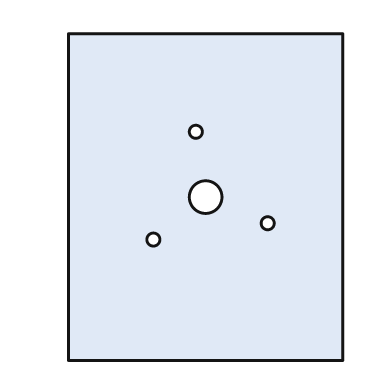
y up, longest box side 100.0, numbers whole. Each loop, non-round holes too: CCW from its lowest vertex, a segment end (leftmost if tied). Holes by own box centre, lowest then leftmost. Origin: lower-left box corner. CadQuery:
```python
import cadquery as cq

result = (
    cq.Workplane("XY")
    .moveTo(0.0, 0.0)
    .lineTo(84.0, 0.0)
    .lineTo(84.0, 100.0)
    .lineTo(0.0, 100.0)
    .close()
    .moveTo(26.0, 37.0)
    .circle(2.0)
    .moveTo(61.0, 42.0)
    .circle(2.0)
    .moveTo(42.0, 50.0)
    .circle(5.0)
    .moveTo(39.0, 70.0)
    .circle(2.0)
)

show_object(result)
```